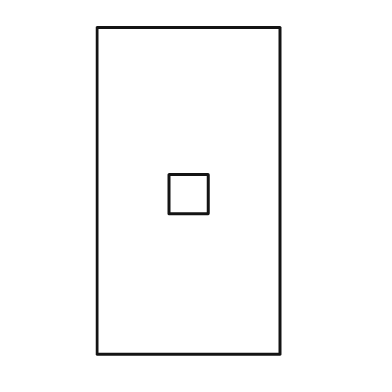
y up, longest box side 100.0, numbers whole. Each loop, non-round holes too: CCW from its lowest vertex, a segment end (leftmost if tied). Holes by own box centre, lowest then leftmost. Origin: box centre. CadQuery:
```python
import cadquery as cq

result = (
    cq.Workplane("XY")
    .moveTo(-28.0, -50.0)
    .lineTo(28.0, -50.0)
    .lineTo(28.0, 50.0)
    .lineTo(-28.0, 50.0)
    .close()
    .moveTo(-6.0, -7.0)
    .lineTo(6.0, -7.0)
    .lineTo(6.0, 5.0)
    .lineTo(-6.0, 5.0)
    .close()
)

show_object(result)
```